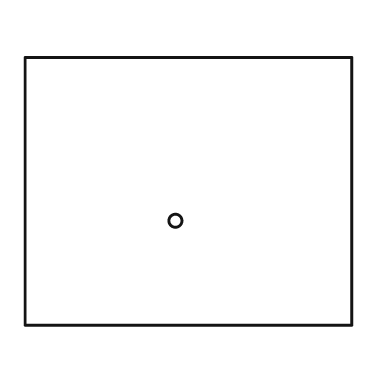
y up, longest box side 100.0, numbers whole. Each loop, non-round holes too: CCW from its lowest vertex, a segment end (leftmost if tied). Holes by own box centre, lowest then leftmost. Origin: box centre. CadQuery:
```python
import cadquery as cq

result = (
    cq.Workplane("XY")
    .moveTo(-50.0, -41.0)
    .lineTo(50.0, -41.0)
    .lineTo(50.0, 41.0)
    .lineTo(-50.0, 41.0)
    .close()
    .moveTo(-4.0, -9.0)
    .circle(2.0)
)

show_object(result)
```